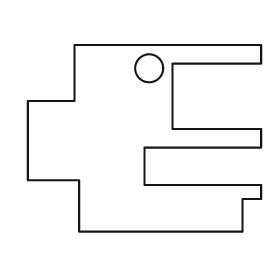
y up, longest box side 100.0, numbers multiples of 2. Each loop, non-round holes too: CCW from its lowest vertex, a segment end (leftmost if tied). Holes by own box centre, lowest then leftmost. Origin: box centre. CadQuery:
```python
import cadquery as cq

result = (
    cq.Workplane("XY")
    .moveTo(-28.0, -40.0)
    .lineTo(42.0, -40.0)
    .lineTo(42.0, -26.0)
    .lineTo(50.0, -26.0)
    .lineTo(50.0, -20.0)
    .lineTo(0.0, -20.0)
    .lineTo(0.0, -4.0)
    .lineTo(50.0, -4.0)
    .lineTo(50.0, 4.0)
    .lineTo(12.0, 4.0)
    .lineTo(12.0, 32.0)
    .lineTo(50.0, 32.0)
    .lineTo(50.0, 40.0)
    .lineTo(-30.0, 40.0)
    .lineTo(-30.0, 16.0)
    .lineTo(-50.0, 16.0)
    .lineTo(-50.0, -18.0)
    .lineTo(-28.0, -18.0)
    .close()
    .moveTo(2.0, 30.0)
    .circle(6.0)
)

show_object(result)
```